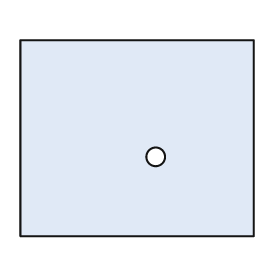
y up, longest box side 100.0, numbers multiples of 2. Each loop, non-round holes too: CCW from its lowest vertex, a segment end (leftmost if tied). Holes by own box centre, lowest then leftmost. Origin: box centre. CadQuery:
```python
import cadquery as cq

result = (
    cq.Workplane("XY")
    .moveTo(-50.0, -42.0)
    .lineTo(50.0, -42.0)
    .lineTo(50.0, 42.0)
    .lineTo(-50.0, 42.0)
    .close()
    .moveTo(8.0, -8.0)
    .circle(4.0)
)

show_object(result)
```